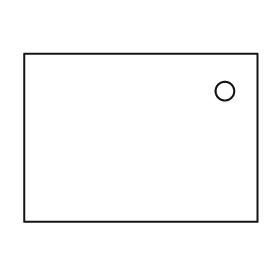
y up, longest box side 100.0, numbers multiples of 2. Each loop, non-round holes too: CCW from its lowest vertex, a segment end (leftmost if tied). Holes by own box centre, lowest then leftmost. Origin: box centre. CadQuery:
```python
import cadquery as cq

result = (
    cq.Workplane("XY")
    .moveTo(-50.0, -36.0)
    .lineTo(50.0, -36.0)
    .lineTo(50.0, 36.0)
    .lineTo(-50.0, 36.0)
    .close()
    .moveTo(36.0, 20.0)
    .circle(4.0)
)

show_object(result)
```